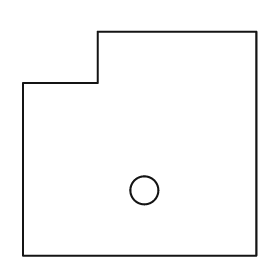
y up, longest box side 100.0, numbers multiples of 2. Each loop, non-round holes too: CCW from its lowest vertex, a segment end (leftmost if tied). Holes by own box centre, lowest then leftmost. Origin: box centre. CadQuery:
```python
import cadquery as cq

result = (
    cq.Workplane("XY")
    .moveTo(-50.0, -48.0)
    .lineTo(50.0, -48.0)
    .lineTo(50.0, 48.0)
    .lineTo(-18.0, 48.0)
    .lineTo(-18.0, 26.0)
    .lineTo(-50.0, 26.0)
    .close()
    .moveTo(2.0, -20.0)
    .circle(6.0)
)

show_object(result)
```